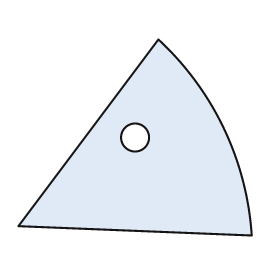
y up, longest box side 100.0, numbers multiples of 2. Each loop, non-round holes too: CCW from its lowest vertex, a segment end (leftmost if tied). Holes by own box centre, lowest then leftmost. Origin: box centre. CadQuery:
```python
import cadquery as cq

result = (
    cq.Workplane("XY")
    .moveTo(50.0, -42.0)
    .threePointArc((38.0, 4.0), (10.0, 42.0))
    .lineTo(-50.0, -38.0)
    .close()
    .moveTo(0.0, 0.0)
    .circle(6.0)
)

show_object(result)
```